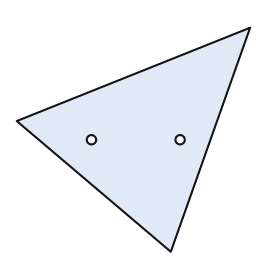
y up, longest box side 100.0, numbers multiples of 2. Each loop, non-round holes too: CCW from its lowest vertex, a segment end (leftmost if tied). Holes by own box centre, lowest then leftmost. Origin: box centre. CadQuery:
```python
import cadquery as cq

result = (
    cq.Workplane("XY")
    .moveTo(16.0, -48.0)
    .lineTo(50.0, 48.0)
    .lineTo(-50.0, 8.0)
    .close()
    .moveTo(-18.0, 0.0)
    .circle(2.0)
    .moveTo(20.0, 0.0)
    .circle(2.0)
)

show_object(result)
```